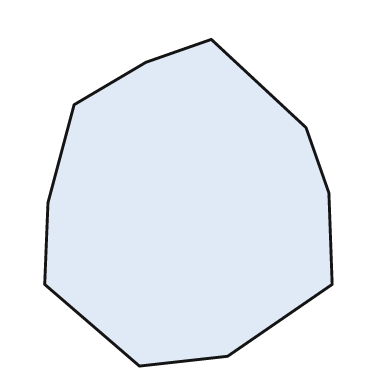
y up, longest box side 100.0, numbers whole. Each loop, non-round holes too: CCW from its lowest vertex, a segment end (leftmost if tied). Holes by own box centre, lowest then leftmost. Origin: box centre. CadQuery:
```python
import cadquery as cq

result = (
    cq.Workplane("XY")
    .moveTo(-15.0, -50.0)
    .lineTo(12.0, -47.0)
    .lineTo(44.0, -25.0)
    .lineTo(43.0, 3.0)
    .lineTo(36.0, 23.0)
    .lineTo(7.0, 50.0)
    .lineTo(-13.0, 43.0)
    .lineTo(-35.0, 30.0)
    .lineTo(-43.0, 0.0)
    .lineTo(-44.0, -25.0)
    .close()
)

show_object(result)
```